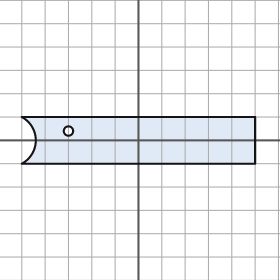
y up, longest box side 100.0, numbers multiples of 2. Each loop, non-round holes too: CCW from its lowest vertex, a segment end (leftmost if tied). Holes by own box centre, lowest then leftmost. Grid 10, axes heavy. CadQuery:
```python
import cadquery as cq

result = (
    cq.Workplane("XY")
    .moveTo(-50.0, -10.0)
    .lineTo(50.0, -10.0)
    .lineTo(50.0, 10.0)
    .lineTo(-50.0, 10.0)
    .threePointArc((-44.0, 0.0), (-50.0, -10.0))
    .close()
    .moveTo(-30.0, 4.0)
    .circle(2.0)
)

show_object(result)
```